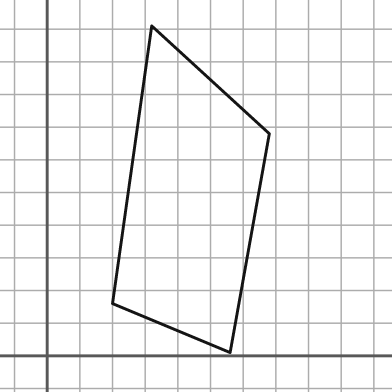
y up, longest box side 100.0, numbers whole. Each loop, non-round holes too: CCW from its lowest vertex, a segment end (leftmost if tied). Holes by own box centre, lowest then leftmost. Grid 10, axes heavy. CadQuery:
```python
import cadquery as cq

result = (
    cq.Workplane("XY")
    .moveTo(56.0, 1.0)
    .lineTo(68.0, 68.0)
    .lineTo(32.0, 101.0)
    .lineTo(20.0, 16.0)
    .close()
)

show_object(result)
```